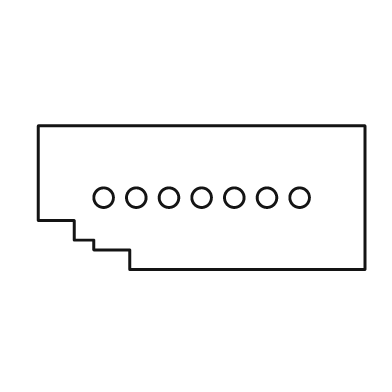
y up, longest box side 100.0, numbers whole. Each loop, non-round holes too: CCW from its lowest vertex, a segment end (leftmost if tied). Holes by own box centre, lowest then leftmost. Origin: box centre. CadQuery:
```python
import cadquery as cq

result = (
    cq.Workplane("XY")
    .moveTo(-22.0, -22.0)
    .lineTo(50.0, -22.0)
    .lineTo(50.0, 22.0)
    .lineTo(-50.0, 22.0)
    .lineTo(-50.0, -7.0)
    .lineTo(-39.0, -7.0)
    .lineTo(-39.0, -13.0)
    .lineTo(-33.0, -13.0)
    .lineTo(-33.0, -16.0)
    .lineTo(-22.0, -16.0)
    .close()
    .moveTo(-30.0, 0.0)
    .circle(3.0)
    .moveTo(-20.0, 0.0)
    .circle(3.0)
    .moveTo(-10.0, 0.0)
    .circle(3.0)
    .moveTo(0.0, 0.0)
    .circle(3.0)
    .moveTo(10.0, 0.0)
    .circle(3.0)
    .moveTo(20.0, 0.0)
    .circle(3.0)
    .moveTo(30.0, 0.0)
    .circle(3.0)
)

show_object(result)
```